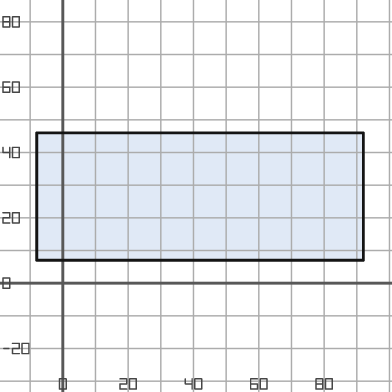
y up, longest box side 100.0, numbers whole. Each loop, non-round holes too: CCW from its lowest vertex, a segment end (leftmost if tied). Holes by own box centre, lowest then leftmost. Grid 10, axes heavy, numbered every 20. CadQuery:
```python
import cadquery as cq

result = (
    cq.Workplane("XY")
    .moveTo(-8.0, 7.0)
    .lineTo(92.0, 7.0)
    .lineTo(92.0, 46.0)
    .lineTo(-8.0, 46.0)
    .close()
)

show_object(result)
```